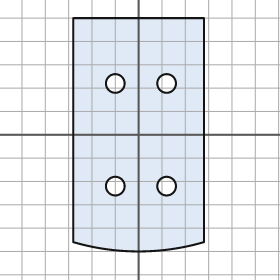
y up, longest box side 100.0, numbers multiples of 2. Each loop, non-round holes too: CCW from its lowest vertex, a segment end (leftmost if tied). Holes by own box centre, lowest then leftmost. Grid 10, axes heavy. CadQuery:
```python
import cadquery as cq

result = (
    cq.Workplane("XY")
    .moveTo(-28.0, -46.0)
    .threePointArc((0.0, -50.0), (28.0, -46.0))
    .lineTo(28.0, 50.0)
    .lineTo(-28.0, 50.0)
    .close()
    .moveTo(-10.0, -22.0)
    .circle(4.0)
    .moveTo(12.0, -22.0)
    .circle(4.0)
    .moveTo(-10.0, 22.0)
    .circle(4.0)
    .moveTo(12.0, 22.0)
    .circle(4.0)
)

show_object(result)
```